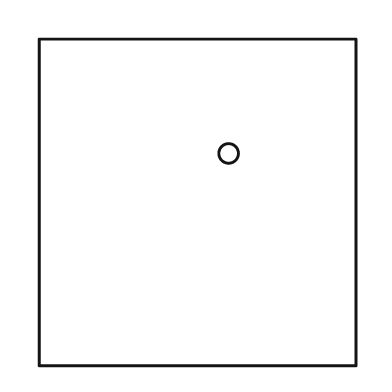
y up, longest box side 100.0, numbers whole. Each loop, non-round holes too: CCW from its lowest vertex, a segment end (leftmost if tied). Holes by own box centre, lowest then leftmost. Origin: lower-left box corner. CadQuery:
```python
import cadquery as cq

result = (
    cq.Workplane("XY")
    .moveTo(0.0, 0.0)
    .lineTo(97.0, 0.0)
    .lineTo(97.0, 100.0)
    .lineTo(0.0, 100.0)
    .close()
    .moveTo(58.0, 65.0)
    .circle(3.0)
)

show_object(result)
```